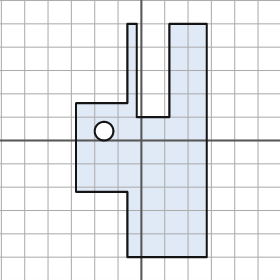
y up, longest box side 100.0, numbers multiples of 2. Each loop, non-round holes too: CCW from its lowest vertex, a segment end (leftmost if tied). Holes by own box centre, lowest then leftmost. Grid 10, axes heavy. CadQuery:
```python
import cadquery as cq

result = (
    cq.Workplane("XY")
    .moveTo(-6.0, -50.0)
    .lineTo(28.0, -50.0)
    .lineTo(28.0, 50.0)
    .lineTo(12.0, 50.0)
    .lineTo(12.0, 10.0)
    .lineTo(-2.0, 10.0)
    .lineTo(-2.0, 50.0)
    .lineTo(-6.0, 50.0)
    .lineTo(-6.0, 16.0)
    .lineTo(-28.0, 16.0)
    .lineTo(-28.0, -22.0)
    .lineTo(-6.0, -22.0)
    .close()
    .moveTo(-16.0, 4.0)
    .circle(4.0)
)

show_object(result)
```